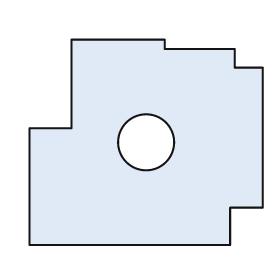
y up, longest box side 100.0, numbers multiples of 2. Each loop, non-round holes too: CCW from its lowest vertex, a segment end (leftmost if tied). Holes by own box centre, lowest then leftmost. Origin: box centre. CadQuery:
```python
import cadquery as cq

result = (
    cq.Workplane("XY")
    .moveTo(-50.0, -44.0)
    .lineTo(36.0, -44.0)
    .lineTo(36.0, -28.0)
    .lineTo(50.0, -28.0)
    .lineTo(50.0, 32.0)
    .lineTo(38.0, 32.0)
    .lineTo(38.0, 40.0)
    .lineTo(8.0, 40.0)
    .lineTo(8.0, 44.0)
    .lineTo(-32.0, 44.0)
    .lineTo(-32.0, 6.0)
    .lineTo(-50.0, 6.0)
    .close()
    .moveTo(0.0, 0.0)
    .circle(12.0)
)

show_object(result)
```